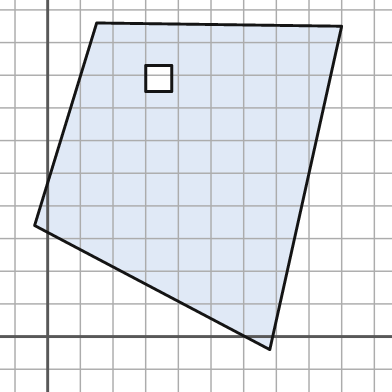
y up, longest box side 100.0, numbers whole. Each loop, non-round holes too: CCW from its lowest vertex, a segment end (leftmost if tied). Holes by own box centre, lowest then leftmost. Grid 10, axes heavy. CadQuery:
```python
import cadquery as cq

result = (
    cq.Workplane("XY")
    .moveTo(68.0, -4.0)
    .lineTo(90.0, 95.0)
    .lineTo(15.0, 96.0)
    .lineTo(-4.0, 34.0)
    .close()
    .moveTo(30.0, 75.0)
    .lineTo(38.0, 75.0)
    .lineTo(38.0, 83.0)
    .lineTo(30.0, 83.0)
    .close()
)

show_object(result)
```